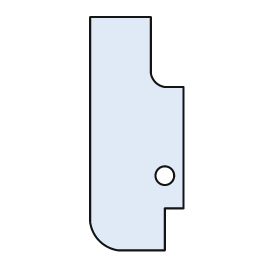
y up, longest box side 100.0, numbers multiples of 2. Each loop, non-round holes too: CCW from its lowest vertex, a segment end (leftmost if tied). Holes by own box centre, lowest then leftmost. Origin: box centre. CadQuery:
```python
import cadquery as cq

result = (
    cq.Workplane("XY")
    .moveTo(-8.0, -50.0)
    .lineTo(12.0, -50.0)
    .lineTo(12.0, -32.0)
    .lineTo(20.0, -32.0)
    .lineTo(20.0, 20.0)
    .lineTo(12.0, 20.0)
    .threePointArc((8.0, 22.0), (6.0, 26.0))
    .lineTo(6.0, 50.0)
    .lineTo(-20.0, 50.0)
    .lineTo(-20.0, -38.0)
    .threePointArc((-16.0, -46.0), (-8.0, -50.0))
    .close()
    .moveTo(12.0, -18.0)
    .circle(4.0)
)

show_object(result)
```